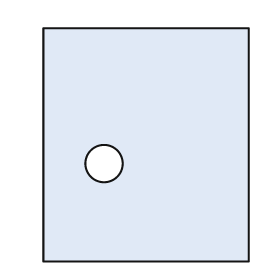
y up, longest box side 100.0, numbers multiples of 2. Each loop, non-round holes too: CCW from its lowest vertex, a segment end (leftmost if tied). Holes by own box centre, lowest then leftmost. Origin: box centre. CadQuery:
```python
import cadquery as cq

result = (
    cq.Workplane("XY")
    .moveTo(-44.0, -50.0)
    .lineTo(44.0, -50.0)
    .lineTo(44.0, 50.0)
    .lineTo(-44.0, 50.0)
    .close()
    .moveTo(-18.0, -8.0)
    .circle(8.0)
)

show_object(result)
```